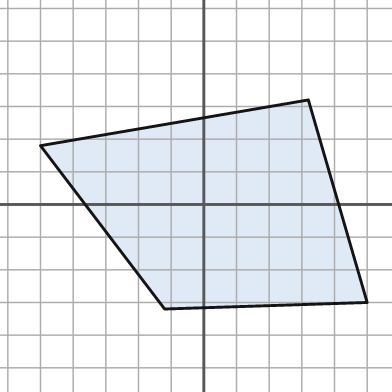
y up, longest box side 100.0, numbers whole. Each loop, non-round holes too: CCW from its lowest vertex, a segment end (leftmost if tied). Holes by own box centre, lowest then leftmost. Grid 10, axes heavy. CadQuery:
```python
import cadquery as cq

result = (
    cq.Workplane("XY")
    .moveTo(-12.0, -32.0)
    .lineTo(50.0, -30.0)
    .lineTo(32.0, 32.0)
    .lineTo(-50.0, 18.0)
    .close()
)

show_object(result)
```